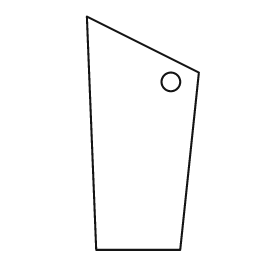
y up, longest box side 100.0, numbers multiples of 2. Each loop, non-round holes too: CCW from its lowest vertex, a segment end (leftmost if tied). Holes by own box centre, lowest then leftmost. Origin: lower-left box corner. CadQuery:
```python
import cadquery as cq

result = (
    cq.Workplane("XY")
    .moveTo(4.0, 0.0)
    .lineTo(40.0, 0.0)
    .lineTo(48.0, 76.0)
    .lineTo(0.0, 100.0)
    .close()
    .moveTo(36.0, 72.0)
    .circle(4.0)
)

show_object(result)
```